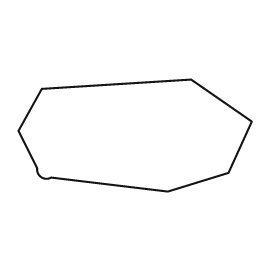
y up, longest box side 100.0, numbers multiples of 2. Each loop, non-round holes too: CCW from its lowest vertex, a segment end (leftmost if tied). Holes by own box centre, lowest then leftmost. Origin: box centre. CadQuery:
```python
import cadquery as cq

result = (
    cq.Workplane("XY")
    .moveTo(14.0, -24.0)
    .lineTo(40.0, -16.0)
    .lineTo(50.0, 6.0)
    .lineTo(24.0, 24.0)
    .lineTo(-40.0, 20.0)
    .lineTo(-50.0, 2.0)
    .lineTo(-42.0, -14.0)
    .threePointArc((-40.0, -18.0), (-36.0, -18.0))
    .close()
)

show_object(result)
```